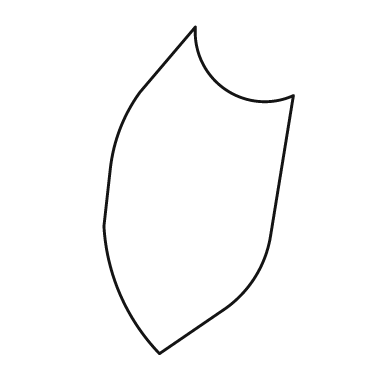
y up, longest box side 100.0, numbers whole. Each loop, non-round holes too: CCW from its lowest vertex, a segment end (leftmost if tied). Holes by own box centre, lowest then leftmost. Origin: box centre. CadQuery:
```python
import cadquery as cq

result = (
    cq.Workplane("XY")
    .moveTo(-12.0, -50.0)
    .lineTo(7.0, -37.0)
    .threePointArc((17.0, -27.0), (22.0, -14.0))
    .lineTo(29.0, 29.0)
    .threePointArc((8.0, 31.0), (-1.0, 50.0))
    .lineTo(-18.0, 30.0)
    .threePointArc((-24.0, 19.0), (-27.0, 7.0))
    .lineTo(-29.0, -11.0)
    .threePointArc((-24.0, -32.0), (-12.0, -50.0))
    .close()
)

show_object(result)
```